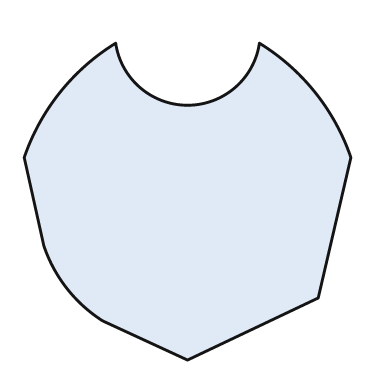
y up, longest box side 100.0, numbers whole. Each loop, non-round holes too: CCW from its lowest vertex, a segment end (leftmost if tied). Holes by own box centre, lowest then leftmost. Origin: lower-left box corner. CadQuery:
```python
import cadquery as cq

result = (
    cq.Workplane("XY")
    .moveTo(50.0, 0.0)
    .lineTo(90.0, 19.0)
    .lineTo(100.0, 62.0)
    .threePointArc((89.0, 82.0), (72.0, 97.0))
    .threePointArc((50.0, 78.0), (28.0, 97.0))
    .threePointArc((11.0, 82.0), (0.0, 62.0))
    .lineTo(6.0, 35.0)
    .threePointArc((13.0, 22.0), (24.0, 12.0))
    .close()
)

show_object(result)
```